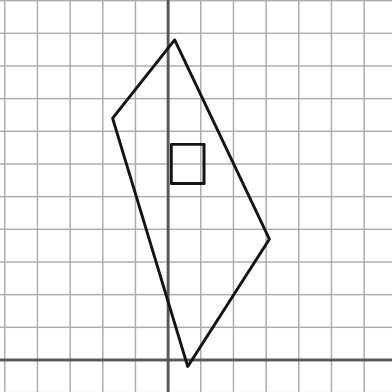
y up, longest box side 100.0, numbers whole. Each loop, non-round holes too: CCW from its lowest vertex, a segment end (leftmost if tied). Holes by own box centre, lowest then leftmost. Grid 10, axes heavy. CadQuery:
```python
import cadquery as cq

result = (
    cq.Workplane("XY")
    .moveTo(6.0, -2.0)
    .lineTo(31.0, 37.0)
    .lineTo(2.0, 98.0)
    .lineTo(-17.0, 74.0)
    .close()
    .moveTo(1.0, 54.0)
    .lineTo(11.0, 54.0)
    .lineTo(11.0, 66.0)
    .lineTo(1.0, 66.0)
    .close()
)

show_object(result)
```